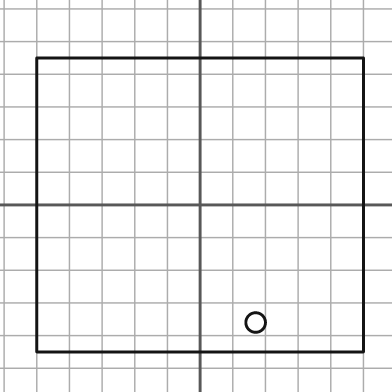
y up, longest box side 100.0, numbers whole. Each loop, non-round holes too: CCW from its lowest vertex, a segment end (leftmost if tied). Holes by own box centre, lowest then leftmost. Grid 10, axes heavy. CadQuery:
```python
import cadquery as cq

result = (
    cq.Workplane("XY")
    .moveTo(-50.0, -45.0)
    .lineTo(50.0, -45.0)
    .lineTo(50.0, 45.0)
    .lineTo(-50.0, 45.0)
    .close()
    .moveTo(17.0, -36.0)
    .circle(3.0)
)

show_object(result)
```